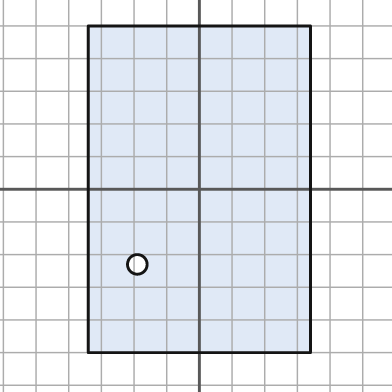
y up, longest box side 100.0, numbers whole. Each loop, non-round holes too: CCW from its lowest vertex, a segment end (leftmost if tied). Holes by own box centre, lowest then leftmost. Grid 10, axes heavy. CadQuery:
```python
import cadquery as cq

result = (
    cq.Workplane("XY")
    .moveTo(-34.0, -50.0)
    .lineTo(34.0, -50.0)
    .lineTo(34.0, 50.0)
    .lineTo(-34.0, 50.0)
    .close()
    .moveTo(-19.0, -23.0)
    .circle(3.0)
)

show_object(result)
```